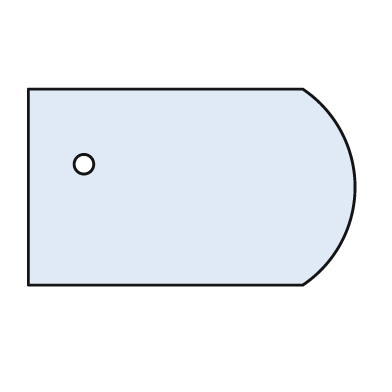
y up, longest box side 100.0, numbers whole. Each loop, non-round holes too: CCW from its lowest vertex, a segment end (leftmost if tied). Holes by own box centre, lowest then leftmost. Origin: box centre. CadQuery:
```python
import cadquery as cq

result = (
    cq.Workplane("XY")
    .moveTo(-50.0, -30.0)
    .lineTo(34.0, -30.0)
    .threePointArc((50.0, 0.0), (34.0, 30.0))
    .lineTo(-50.0, 30.0)
    .close()
    .moveTo(-33.0, 7.0)
    .circle(3.0)
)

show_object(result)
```